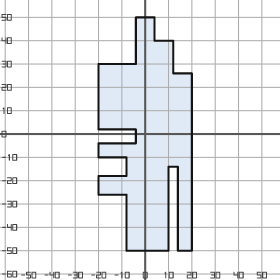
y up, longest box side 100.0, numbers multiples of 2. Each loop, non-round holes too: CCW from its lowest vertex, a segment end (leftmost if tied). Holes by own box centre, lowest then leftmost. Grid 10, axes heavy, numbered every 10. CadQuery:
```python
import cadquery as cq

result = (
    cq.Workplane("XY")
    .moveTo(-8.0, -50.0)
    .lineTo(10.0, -50.0)
    .lineTo(10.0, -14.0)
    .lineTo(14.0, -14.0)
    .lineTo(14.0, -50.0)
    .lineTo(20.0, -50.0)
    .lineTo(20.0, 26.0)
    .lineTo(12.0, 26.0)
    .lineTo(12.0, 40.0)
    .lineTo(4.0, 40.0)
    .lineTo(4.0, 50.0)
    .lineTo(-4.0, 50.0)
    .lineTo(-4.0, 30.0)
    .lineTo(-20.0, 30.0)
    .lineTo(-20.0, 2.0)
    .lineTo(-4.0, 2.0)
    .lineTo(-4.0, -4.0)
    .lineTo(-20.0, -4.0)
    .lineTo(-20.0, -10.0)
    .lineTo(-8.0, -10.0)
    .lineTo(-8.0, -18.0)
    .lineTo(-20.0, -18.0)
    .lineTo(-20.0, -26.0)
    .lineTo(-8.0, -26.0)
    .close()
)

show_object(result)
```